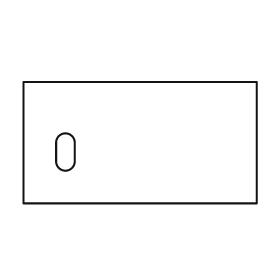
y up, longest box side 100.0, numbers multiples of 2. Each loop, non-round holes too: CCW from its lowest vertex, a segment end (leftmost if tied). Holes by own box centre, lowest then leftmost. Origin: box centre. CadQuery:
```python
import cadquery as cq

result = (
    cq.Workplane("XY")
    .moveTo(-50.0, -26.0)
    .lineTo(50.0, -26.0)
    .lineTo(50.0, 26.0)
    .lineTo(-50.0, 26.0)
    .close()
    .moveTo(-36.0, -8.0)
    .threePointArc((-32.0, -12.0), (-28.0, -8.0))
    .lineTo(-28.0, 0.0)
    .threePointArc((-32.0, 4.0), (-36.0, 0.0))
    .close()
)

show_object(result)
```